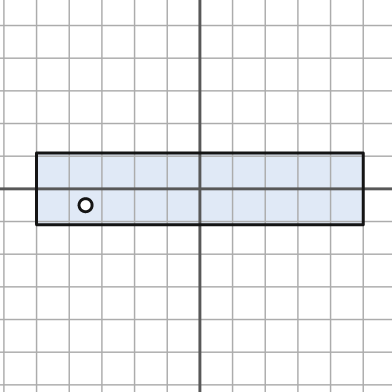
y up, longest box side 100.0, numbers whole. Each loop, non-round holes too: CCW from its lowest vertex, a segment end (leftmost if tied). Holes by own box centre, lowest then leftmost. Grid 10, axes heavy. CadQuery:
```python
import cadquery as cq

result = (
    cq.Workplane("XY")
    .moveTo(-50.0, -11.0)
    .lineTo(50.0, -11.0)
    .lineTo(50.0, 11.0)
    .lineTo(-50.0, 11.0)
    .close()
    .moveTo(-35.0, -5.0)
    .circle(2.0)
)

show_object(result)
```